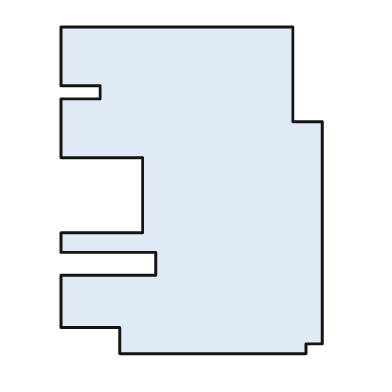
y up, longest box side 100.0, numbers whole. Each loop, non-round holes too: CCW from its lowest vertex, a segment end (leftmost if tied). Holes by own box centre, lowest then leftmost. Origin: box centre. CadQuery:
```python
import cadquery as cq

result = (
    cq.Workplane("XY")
    .moveTo(-22.0, -50.0)
    .lineTo(35.0, -50.0)
    .lineTo(35.0, -47.0)
    .lineTo(40.0, -47.0)
    .lineTo(40.0, 21.0)
    .lineTo(31.0, 21.0)
    .lineTo(31.0, 50.0)
    .lineTo(-40.0, 50.0)
    .lineTo(-40.0, 32.0)
    .lineTo(-28.0, 32.0)
    .lineTo(-28.0, 28.0)
    .lineTo(-40.0, 28.0)
    .lineTo(-40.0, 10.0)
    .lineTo(-15.0, 10.0)
    .lineTo(-15.0, -13.0)
    .lineTo(-40.0, -13.0)
    .lineTo(-40.0, -19.0)
    .lineTo(-11.0, -19.0)
    .lineTo(-11.0, -26.0)
    .lineTo(-40.0, -26.0)
    .lineTo(-40.0, -42.0)
    .lineTo(-22.0, -42.0)
    .close()
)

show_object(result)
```